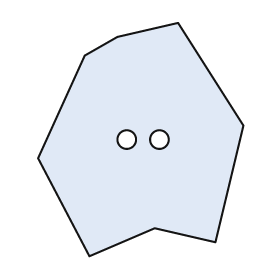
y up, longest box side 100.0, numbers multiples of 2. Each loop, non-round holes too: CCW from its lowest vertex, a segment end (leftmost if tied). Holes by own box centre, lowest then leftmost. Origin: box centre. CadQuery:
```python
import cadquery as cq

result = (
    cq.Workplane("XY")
    .moveTo(-22.0, -50.0)
    .lineTo(6.0, -38.0)
    .lineTo(32.0, -44.0)
    .lineTo(44.0, 6.0)
    .lineTo(16.0, 50.0)
    .lineTo(-10.0, 44.0)
    .lineTo(-24.0, 36.0)
    .lineTo(-44.0, -8.0)
    .close()
    .moveTo(-6.0, 0.0)
    .circle(4.0)
    .moveTo(8.0, 0.0)
    .circle(4.0)
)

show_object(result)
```